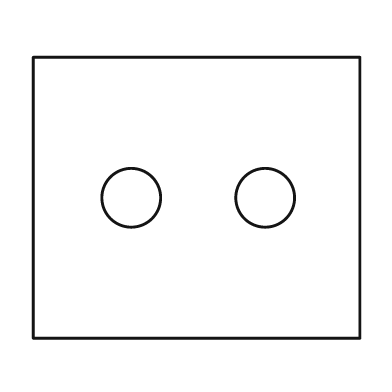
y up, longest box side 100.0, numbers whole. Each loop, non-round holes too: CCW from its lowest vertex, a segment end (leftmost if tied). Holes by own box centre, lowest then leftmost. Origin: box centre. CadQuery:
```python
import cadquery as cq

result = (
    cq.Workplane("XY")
    .moveTo(-50.0, -43.0)
    .lineTo(50.0, -43.0)
    .lineTo(50.0, 43.0)
    .lineTo(-50.0, 43.0)
    .close()
    .moveTo(-20.0, 0.0)
    .circle(9.0)
    .moveTo(21.0, 0.0)
    .circle(9.0)
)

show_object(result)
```